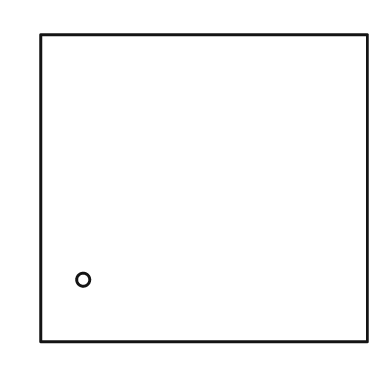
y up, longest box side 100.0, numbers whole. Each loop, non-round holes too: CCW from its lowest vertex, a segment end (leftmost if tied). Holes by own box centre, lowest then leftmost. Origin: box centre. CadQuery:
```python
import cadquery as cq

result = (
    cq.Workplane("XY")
    .moveTo(-50.0, -47.0)
    .lineTo(50.0, -47.0)
    .lineTo(50.0, 47.0)
    .lineTo(-50.0, 47.0)
    .close()
    .moveTo(-37.0, -28.0)
    .circle(2.0)
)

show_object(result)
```